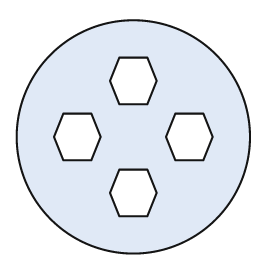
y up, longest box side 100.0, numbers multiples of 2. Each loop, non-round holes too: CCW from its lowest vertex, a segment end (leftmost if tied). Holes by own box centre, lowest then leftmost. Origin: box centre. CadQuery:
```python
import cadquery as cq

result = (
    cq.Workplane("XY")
    .moveTo(0.0, 0.0)
    .circle(50.0)
    .moveTo(-6.0, -34.0)
    .lineTo(6.0, -34.0)
    .lineTo(10.0, -24.0)
    .lineTo(6.0, -14.0)
    .lineTo(-6.0, -14.0)
    .lineTo(-10.0, -24.0)
    .close()
    .moveTo(-30.0, -10.0)
    .lineTo(-18.0, -10.0)
    .lineTo(-14.0, 0.0)
    .lineTo(-18.0, 10.0)
    .lineTo(-30.0, 10.0)
    .lineTo(-34.0, 0.0)
    .close()
    .moveTo(18.0, -10.0)
    .lineTo(30.0, -10.0)
    .lineTo(34.0, 0.0)
    .lineTo(30.0, 10.0)
    .lineTo(18.0, 10.0)
    .lineTo(14.0, 0.0)
    .close()
    .moveTo(-6.0, 14.0)
    .lineTo(6.0, 14.0)
    .lineTo(10.0, 24.0)
    .lineTo(6.0, 34.0)
    .lineTo(-6.0, 34.0)
    .lineTo(-10.0, 24.0)
    .close()
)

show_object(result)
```